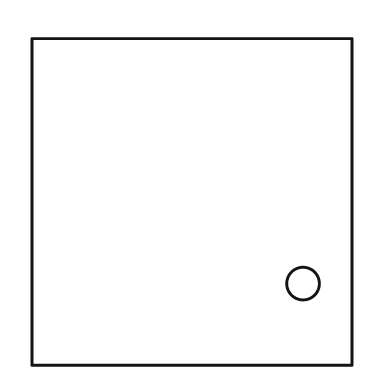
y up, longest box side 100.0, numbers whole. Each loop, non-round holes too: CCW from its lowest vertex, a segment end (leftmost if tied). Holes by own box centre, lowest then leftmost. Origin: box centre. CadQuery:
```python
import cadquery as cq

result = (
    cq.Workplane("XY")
    .moveTo(-49.0, -50.0)
    .lineTo(49.0, -50.0)
    .lineTo(49.0, 50.0)
    .lineTo(-49.0, 50.0)
    .close()
    .moveTo(34.0, -25.0)
    .circle(5.0)
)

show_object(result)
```